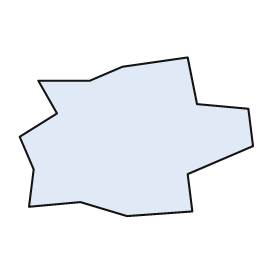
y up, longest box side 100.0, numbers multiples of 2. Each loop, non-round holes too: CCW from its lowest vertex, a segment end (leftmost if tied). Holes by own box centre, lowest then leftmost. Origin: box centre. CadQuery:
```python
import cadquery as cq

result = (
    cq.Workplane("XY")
    .moveTo(-4.0, -34.0)
    .lineTo(24.0, -32.0)
    .lineTo(22.0, -16.0)
    .lineTo(50.0, -4.0)
    .lineTo(48.0, 12.0)
    .lineTo(26.0, 14.0)
    .lineTo(22.0, 34.0)
    .lineTo(-6.0, 30.0)
    .lineTo(-20.0, 24.0)
    .lineTo(-42.0, 24.0)
    .lineTo(-34.0, 10.0)
    .lineTo(-50.0, 0.0)
    .lineTo(-44.0, -14.0)
    .lineTo(-46.0, -30.0)
    .lineTo(-24.0, -28.0)
    .close()
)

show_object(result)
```